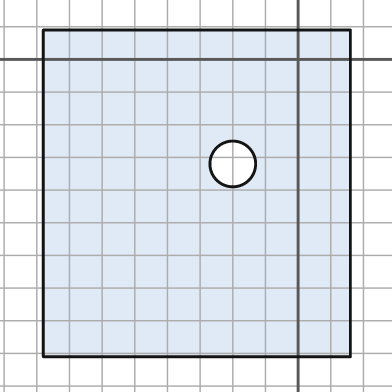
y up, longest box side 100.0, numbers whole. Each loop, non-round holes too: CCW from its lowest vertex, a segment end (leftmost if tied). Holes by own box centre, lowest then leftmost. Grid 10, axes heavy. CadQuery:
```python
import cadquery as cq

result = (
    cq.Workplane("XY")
    .moveTo(-78.0, -91.0)
    .lineTo(16.0, -91.0)
    .lineTo(16.0, 9.0)
    .lineTo(-78.0, 9.0)
    .close()
    .moveTo(-20.0, -32.0)
    .circle(7.0)
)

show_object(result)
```